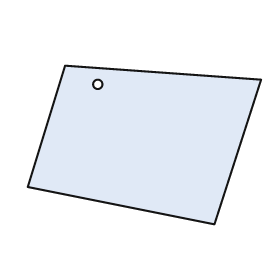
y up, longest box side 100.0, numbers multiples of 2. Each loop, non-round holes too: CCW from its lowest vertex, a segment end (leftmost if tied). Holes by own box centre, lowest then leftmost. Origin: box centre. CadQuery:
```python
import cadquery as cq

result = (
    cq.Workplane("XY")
    .moveTo(30.0, -34.0)
    .lineTo(50.0, 28.0)
    .lineTo(-34.0, 34.0)
    .lineTo(-50.0, -18.0)
    .close()
    .moveTo(-20.0, 26.0)
    .circle(2.0)
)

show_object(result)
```